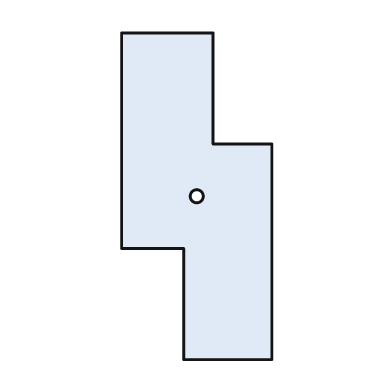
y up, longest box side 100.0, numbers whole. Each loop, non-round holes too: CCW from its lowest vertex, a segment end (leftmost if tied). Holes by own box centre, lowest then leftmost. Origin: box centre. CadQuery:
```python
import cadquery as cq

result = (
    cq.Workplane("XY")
    .moveTo(-4.0, -50.0)
    .lineTo(23.0, -50.0)
    .lineTo(23.0, 16.0)
    .lineTo(5.0, 16.0)
    .lineTo(5.0, 50.0)
    .lineTo(-23.0, 50.0)
    .lineTo(-23.0, -16.0)
    .lineTo(-4.0, -16.0)
    .close()
    .moveTo(0.0, 0.0)
    .circle(2.0)
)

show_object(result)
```